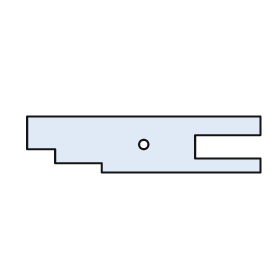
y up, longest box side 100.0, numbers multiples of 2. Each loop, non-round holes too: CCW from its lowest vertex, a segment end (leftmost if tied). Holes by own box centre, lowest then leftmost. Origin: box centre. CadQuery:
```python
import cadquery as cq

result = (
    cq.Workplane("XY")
    .moveTo(-18.0, -12.0)
    .lineTo(50.0, -12.0)
    .lineTo(50.0, -6.0)
    .lineTo(22.0, -6.0)
    .lineTo(22.0, 4.0)
    .lineTo(50.0, 4.0)
    .lineTo(50.0, 12.0)
    .lineTo(-50.0, 12.0)
    .lineTo(-50.0, -2.0)
    .lineTo(-38.0, -2.0)
    .lineTo(-38.0, -8.0)
    .lineTo(-18.0, -8.0)
    .close()
    .moveTo(0.0, 0.0)
    .circle(2.0)
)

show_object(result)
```